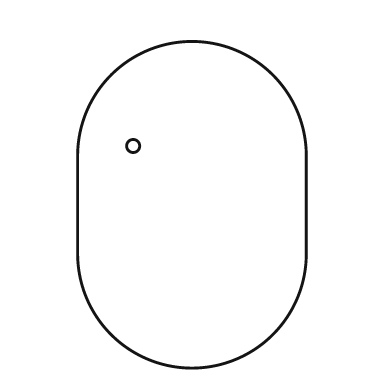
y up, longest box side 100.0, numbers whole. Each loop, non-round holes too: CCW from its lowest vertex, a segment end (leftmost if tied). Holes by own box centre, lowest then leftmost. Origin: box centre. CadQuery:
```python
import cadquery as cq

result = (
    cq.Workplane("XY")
    .moveTo(-35.0, -15.0)
    .threePointArc((0.0, -50.0), (35.0, -15.0))
    .lineTo(35.0, 15.0)
    .threePointArc((0.0, 50.0), (-35.0, 15.0))
    .close()
    .moveTo(-18.0, 18.0)
    .circle(2.0)
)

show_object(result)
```